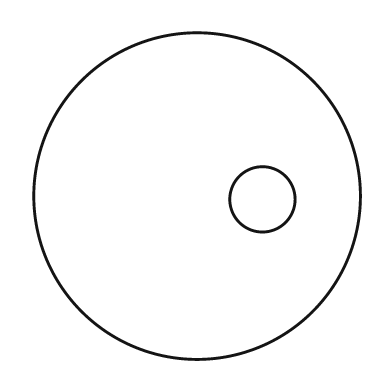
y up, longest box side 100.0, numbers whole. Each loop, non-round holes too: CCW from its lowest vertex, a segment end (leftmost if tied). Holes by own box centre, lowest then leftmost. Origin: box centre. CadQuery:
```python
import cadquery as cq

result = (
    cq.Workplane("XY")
    .moveTo(0.0, 0.0)
    .circle(50.0)
    .moveTo(20.0, -1.0)
    .circle(10.0)
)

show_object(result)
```